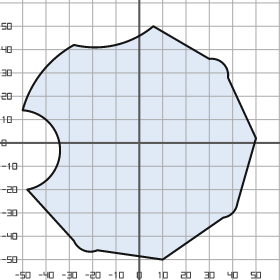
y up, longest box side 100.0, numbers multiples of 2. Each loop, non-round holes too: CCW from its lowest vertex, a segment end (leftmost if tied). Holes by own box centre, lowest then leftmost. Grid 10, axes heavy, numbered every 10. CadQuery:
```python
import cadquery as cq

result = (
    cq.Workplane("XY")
    .moveTo(10.0, -50.0)
    .lineTo(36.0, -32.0)
    .threePointArc((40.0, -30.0), (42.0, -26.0))
    .lineTo(50.0, 2.0)
    .lineTo(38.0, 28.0)
    .threePointArc((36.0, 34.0), (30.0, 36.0))
    .lineTo(6.0, 50.0)
    .threePointArc((-10.0, 42.0), (-28.0, 42.0))
    .threePointArc((-42.0, 30.0), (-50.0, 14.0))
    .threePointArc((-34.0, -2.0), (-48.0, -20.0))
    .lineTo(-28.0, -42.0)
    .threePointArc((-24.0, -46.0), (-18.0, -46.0))
    .close()
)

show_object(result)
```